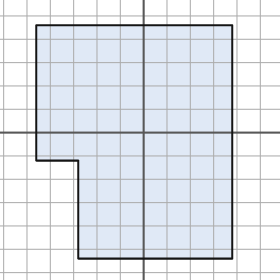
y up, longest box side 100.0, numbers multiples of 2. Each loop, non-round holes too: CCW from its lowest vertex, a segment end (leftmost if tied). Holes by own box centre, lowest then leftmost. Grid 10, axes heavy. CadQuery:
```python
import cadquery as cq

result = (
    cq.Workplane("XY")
    .moveTo(-28.0, -54.0)
    .lineTo(38.0, -54.0)
    .lineTo(38.0, 46.0)
    .lineTo(-46.0, 46.0)
    .lineTo(-46.0, -12.0)
    .lineTo(-28.0, -12.0)
    .close()
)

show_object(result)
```